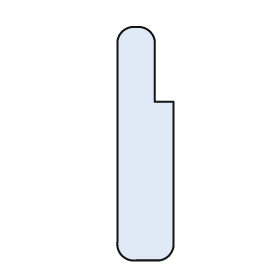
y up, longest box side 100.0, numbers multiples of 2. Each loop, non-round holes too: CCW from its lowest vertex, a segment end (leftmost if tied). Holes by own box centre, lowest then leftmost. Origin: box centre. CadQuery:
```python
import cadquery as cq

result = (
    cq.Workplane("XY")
    .moveTo(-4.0, -50.0)
    .lineTo(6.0, -50.0)
    .threePointArc((10.0, -48.0), (12.0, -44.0))
    .lineTo(12.0, 18.0)
    .lineTo(4.0, 18.0)
    .lineTo(4.0, 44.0)
    .threePointArc((2.0, 48.0), (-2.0, 50.0))
    .lineTo(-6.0, 50.0)
    .threePointArc((-10.0, 48.0), (-12.0, 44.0))
    .lineTo(-12.0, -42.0)
    .threePointArc((-10.0, -48.0), (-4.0, -50.0))
    .close()
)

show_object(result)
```